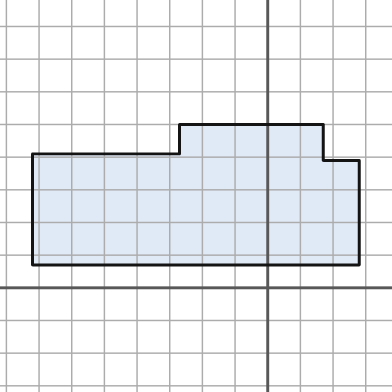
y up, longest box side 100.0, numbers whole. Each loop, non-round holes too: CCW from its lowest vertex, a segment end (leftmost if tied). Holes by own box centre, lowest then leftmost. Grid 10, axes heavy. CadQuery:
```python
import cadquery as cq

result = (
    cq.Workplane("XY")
    .moveTo(-72.0, 7.0)
    .lineTo(28.0, 7.0)
    .lineTo(28.0, 39.0)
    .lineTo(17.0, 39.0)
    .lineTo(17.0, 50.0)
    .lineTo(-27.0, 50.0)
    .lineTo(-27.0, 41.0)
    .lineTo(-72.0, 41.0)
    .close()
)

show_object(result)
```